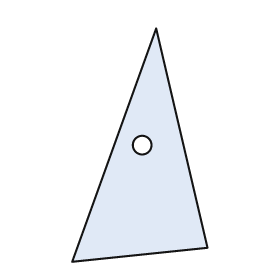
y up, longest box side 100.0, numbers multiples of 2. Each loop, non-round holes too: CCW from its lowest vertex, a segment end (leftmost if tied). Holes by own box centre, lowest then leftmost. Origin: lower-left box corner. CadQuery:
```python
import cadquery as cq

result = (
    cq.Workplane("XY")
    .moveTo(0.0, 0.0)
    .lineTo(58.0, 6.0)
    .lineTo(36.0, 100.0)
    .close()
    .moveTo(30.0, 50.0)
    .circle(4.0)
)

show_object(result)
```